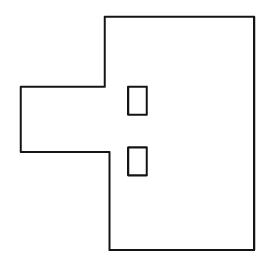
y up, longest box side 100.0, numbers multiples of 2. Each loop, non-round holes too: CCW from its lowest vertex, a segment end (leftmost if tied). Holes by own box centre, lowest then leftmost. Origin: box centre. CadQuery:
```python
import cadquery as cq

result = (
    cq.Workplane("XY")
    .moveTo(-12.0, -50.0)
    .lineTo(50.0, -50.0)
    .lineTo(50.0, 50.0)
    .lineTo(-14.0, 50.0)
    .lineTo(-14.0, 20.0)
    .lineTo(-50.0, 20.0)
    .lineTo(-50.0, -8.0)
    .lineTo(-12.0, -8.0)
    .close()
    .moveTo(-4.0, -18.0)
    .lineTo(4.0, -18.0)
    .lineTo(4.0, -6.0)
    .lineTo(-4.0, -6.0)
    .close()
    .moveTo(-4.0, 8.0)
    .lineTo(4.0, 8.0)
    .lineTo(4.0, 20.0)
    .lineTo(-4.0, 20.0)
    .close()
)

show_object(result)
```